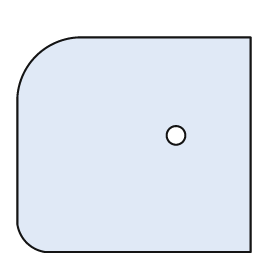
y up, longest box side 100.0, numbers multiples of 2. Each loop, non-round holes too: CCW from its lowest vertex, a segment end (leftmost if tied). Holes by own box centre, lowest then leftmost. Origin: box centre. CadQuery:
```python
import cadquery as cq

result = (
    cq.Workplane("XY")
    .moveTo(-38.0, -46.0)
    .lineTo(50.0, -46.0)
    .lineTo(50.0, 46.0)
    .lineTo(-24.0, 46.0)
    .threePointArc((-42.0, 38.0), (-50.0, 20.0))
    .lineTo(-50.0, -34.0)
    .threePointArc((-46.0, -42.0), (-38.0, -46.0))
    .close()
    .moveTo(18.0, 4.0)
    .circle(4.0)
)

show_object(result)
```